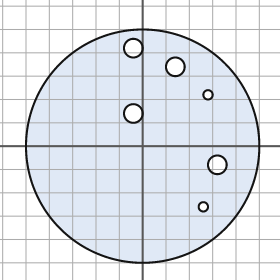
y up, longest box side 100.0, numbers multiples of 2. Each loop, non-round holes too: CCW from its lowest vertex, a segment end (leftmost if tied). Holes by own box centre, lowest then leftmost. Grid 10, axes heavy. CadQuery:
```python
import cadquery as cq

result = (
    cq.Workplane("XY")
    .moveTo(0.0, 0.0)
    .circle(50.0)
    .moveTo(26.0, -26.0)
    .circle(2.0)
    .moveTo(32.0, -8.0)
    .circle(4.0)
    .moveTo(-4.0, 14.0)
    .circle(4.0)
    .moveTo(28.0, 22.0)
    .circle(2.0)
    .moveTo(14.0, 34.0)
    .circle(4.0)
    .moveTo(-4.0, 42.0)
    .circle(4.0)
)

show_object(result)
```